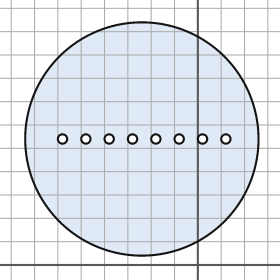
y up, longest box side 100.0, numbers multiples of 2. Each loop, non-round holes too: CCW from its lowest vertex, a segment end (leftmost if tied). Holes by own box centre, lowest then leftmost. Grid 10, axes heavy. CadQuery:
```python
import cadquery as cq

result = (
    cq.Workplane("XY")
    .moveTo(-24.0, 54.0)
    .circle(50.0)
    .moveTo(-58.0, 54.0)
    .circle(2.0)
    .moveTo(-48.0, 54.0)
    .circle(2.0)
    .moveTo(-38.0, 54.0)
    .circle(2.0)
    .moveTo(-28.0, 54.0)
    .circle(2.0)
    .moveTo(-18.0, 54.0)
    .circle(2.0)
    .moveTo(-8.0, 54.0)
    .circle(2.0)
    .moveTo(2.0, 54.0)
    .circle(2.0)
    .moveTo(12.0, 54.0)
    .circle(2.0)
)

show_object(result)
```